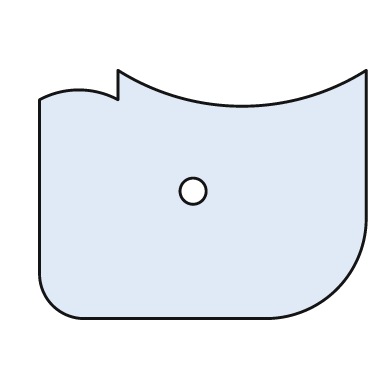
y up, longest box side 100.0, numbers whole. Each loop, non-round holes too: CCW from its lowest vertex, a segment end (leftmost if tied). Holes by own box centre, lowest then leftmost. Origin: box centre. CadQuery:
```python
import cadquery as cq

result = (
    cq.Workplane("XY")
    .moveTo(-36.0, -38.0)
    .lineTo(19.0, -38.0)
    .threePointArc((41.0, -29.0), (50.0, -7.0))
    .lineTo(50.0, 38.0)
    .threePointArc((12.0, 27.0), (-26.0, 38.0))
    .lineTo(-26.0, 29.0)
    .threePointArc((-38.0, 32.0), (-50.0, 29.0))
    .lineTo(-50.0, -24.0)
    .threePointArc((-46.0, -34.0), (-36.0, -38.0))
    .close()
    .moveTo(-3.0, 1.0)
    .circle(4.0)
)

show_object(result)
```